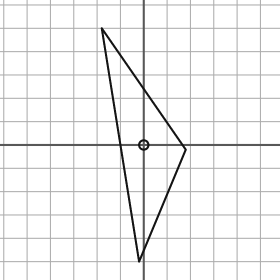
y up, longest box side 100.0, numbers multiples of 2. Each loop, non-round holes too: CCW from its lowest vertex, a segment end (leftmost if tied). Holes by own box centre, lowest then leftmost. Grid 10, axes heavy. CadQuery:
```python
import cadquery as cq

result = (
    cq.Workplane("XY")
    .moveTo(-2.0, -50.0)
    .lineTo(18.0, -2.0)
    .lineTo(-18.0, 50.0)
    .close()
    .moveTo(0.0, 0.0)
    .circle(2.0)
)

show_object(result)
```